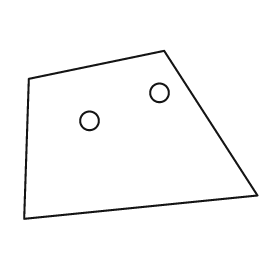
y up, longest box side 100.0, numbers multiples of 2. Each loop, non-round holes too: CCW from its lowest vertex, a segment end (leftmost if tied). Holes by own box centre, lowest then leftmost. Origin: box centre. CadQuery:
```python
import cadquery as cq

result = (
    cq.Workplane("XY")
    .moveTo(-50.0, -36.0)
    .lineTo(50.0, -26.0)
    .lineTo(10.0, 36.0)
    .lineTo(-48.0, 24.0)
    .close()
    .moveTo(-22.0, 6.0)
    .circle(4.0)
    .moveTo(8.0, 18.0)
    .circle(4.0)
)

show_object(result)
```